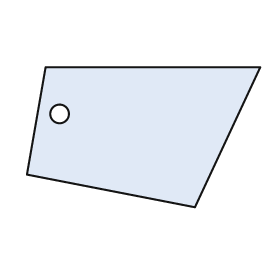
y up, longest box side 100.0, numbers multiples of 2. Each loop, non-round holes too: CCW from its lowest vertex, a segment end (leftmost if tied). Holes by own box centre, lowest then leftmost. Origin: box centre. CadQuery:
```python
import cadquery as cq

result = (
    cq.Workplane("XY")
    .moveTo(22.0, -30.0)
    .lineTo(50.0, 30.0)
    .lineTo(-42.0, 30.0)
    .lineTo(-50.0, -16.0)
    .close()
    .moveTo(-36.0, 10.0)
    .circle(4.0)
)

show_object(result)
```